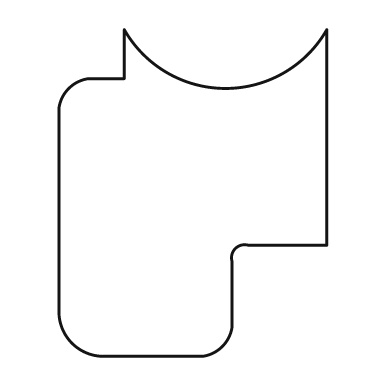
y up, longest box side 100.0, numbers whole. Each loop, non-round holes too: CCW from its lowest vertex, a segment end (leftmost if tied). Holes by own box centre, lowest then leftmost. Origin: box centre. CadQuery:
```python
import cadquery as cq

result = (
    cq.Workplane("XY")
    .moveTo(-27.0, -50.0)
    .lineTo(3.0, -50.0)
    .threePointArc((9.0, -47.0), (12.0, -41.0))
    .lineTo(12.0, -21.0)
    .threePointArc((13.0, -17.0), (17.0, -16.0))
    .lineTo(41.0, -16.0)
    .lineTo(41.0, 50.0)
    .threePointArc((10.0, 32.0), (-21.0, 50.0))
    .lineTo(-21.0, 35.0)
    .lineTo(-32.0, 35.0)
    .threePointArc((-38.0, 32.0), (-41.0, 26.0))
    .lineTo(-41.0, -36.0)
    .threePointArc((-37.0, -46.0), (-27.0, -50.0))
    .close()
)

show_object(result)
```